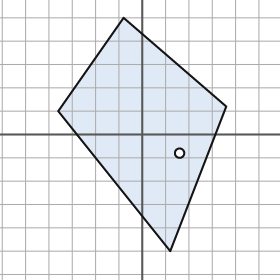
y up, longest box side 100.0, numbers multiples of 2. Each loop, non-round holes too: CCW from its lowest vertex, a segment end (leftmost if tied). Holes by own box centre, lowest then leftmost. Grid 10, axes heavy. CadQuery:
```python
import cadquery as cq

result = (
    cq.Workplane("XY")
    .moveTo(12.0, -50.0)
    .lineTo(36.0, 12.0)
    .lineTo(-8.0, 50.0)
    .lineTo(-36.0, 10.0)
    .close()
    .moveTo(16.0, -8.0)
    .circle(2.0)
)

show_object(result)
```